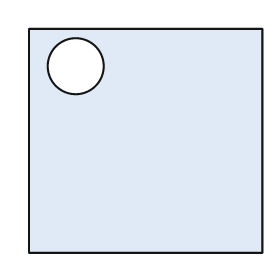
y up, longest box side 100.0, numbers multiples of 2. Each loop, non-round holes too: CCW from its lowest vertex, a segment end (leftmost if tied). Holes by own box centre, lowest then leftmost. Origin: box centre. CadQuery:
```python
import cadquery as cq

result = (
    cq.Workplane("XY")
    .moveTo(-50.0, -48.0)
    .lineTo(50.0, -48.0)
    .lineTo(50.0, 48.0)
    .lineTo(-50.0, 48.0)
    .close()
    .moveTo(-30.0, 32.0)
    .circle(12.0)
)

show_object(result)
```